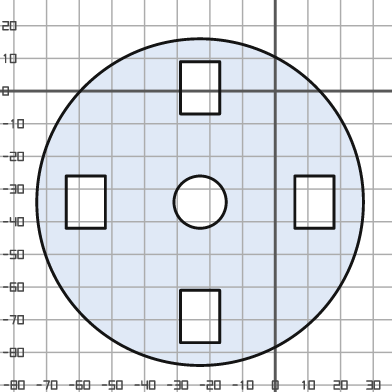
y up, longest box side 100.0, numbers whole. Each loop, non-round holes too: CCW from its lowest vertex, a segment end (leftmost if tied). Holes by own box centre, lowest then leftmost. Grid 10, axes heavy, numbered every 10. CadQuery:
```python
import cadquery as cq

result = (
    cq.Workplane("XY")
    .moveTo(-23.0, -34.0)
    .circle(50.0)
    .moveTo(-29.0, -77.0)
    .lineTo(-17.0, -77.0)
    .lineTo(-17.0, -61.0)
    .lineTo(-29.0, -61.0)
    .close()
    .moveTo(-64.0, -42.0)
    .lineTo(-52.0, -42.0)
    .lineTo(-52.0, -26.0)
    .lineTo(-64.0, -26.0)
    .close()
    .moveTo(-23.0, -34.0)
    .circle(8.0)
    .moveTo(6.0, -42.0)
    .lineTo(18.0, -42.0)
    .lineTo(18.0, -26.0)
    .lineTo(6.0, -26.0)
    .close()
    .moveTo(-29.0, -7.0)
    .lineTo(-17.0, -7.0)
    .lineTo(-17.0, 9.0)
    .lineTo(-29.0, 9.0)
    .close()
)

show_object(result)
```